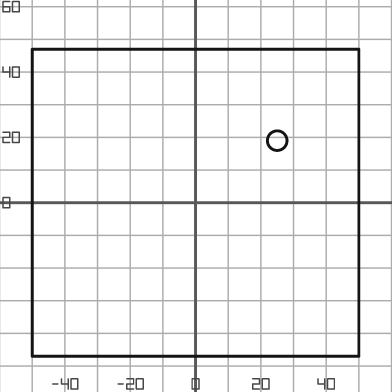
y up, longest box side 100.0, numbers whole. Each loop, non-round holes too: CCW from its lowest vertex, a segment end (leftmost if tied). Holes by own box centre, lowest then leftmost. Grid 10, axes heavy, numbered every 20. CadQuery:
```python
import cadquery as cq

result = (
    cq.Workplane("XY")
    .moveTo(-50.0, -47.0)
    .lineTo(50.0, -47.0)
    .lineTo(50.0, 47.0)
    .lineTo(-50.0, 47.0)
    .close()
    .moveTo(25.0, 19.0)
    .circle(3.0)
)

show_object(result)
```